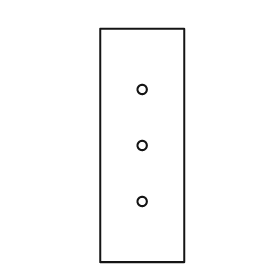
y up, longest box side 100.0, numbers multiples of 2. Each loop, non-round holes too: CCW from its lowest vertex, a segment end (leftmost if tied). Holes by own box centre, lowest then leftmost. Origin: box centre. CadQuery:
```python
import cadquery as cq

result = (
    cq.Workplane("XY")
    .moveTo(-18.0, -50.0)
    .lineTo(18.0, -50.0)
    .lineTo(18.0, 50.0)
    .lineTo(-18.0, 50.0)
    .close()
    .moveTo(0.0, -24.0)
    .circle(2.0)
    .moveTo(0.0, 0.0)
    .circle(2.0)
    .moveTo(0.0, 24.0)
    .circle(2.0)
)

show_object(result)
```